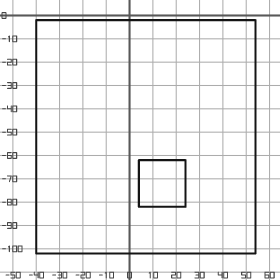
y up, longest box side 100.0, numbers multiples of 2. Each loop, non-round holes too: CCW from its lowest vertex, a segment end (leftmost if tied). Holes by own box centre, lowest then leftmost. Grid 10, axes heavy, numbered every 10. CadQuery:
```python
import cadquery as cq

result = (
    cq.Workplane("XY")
    .moveTo(-40.0, -102.0)
    .lineTo(54.0, -102.0)
    .lineTo(54.0, -2.0)
    .lineTo(-40.0, -2.0)
    .close()
    .moveTo(4.0, -82.0)
    .lineTo(24.0, -82.0)
    .lineTo(24.0, -62.0)
    .lineTo(4.0, -62.0)
    .close()
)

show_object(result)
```